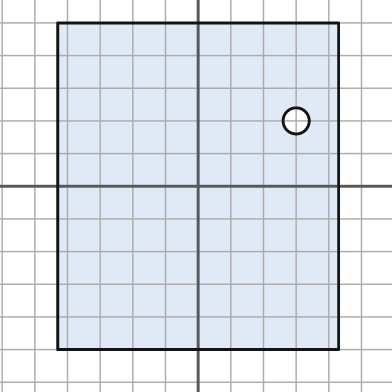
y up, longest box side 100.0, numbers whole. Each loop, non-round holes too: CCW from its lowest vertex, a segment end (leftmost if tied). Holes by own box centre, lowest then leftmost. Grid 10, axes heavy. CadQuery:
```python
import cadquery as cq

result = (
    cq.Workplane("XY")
    .moveTo(-43.0, -50.0)
    .lineTo(43.0, -50.0)
    .lineTo(43.0, 50.0)
    .lineTo(-43.0, 50.0)
    .close()
    .moveTo(30.0, 20.0)
    .circle(4.0)
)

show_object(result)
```